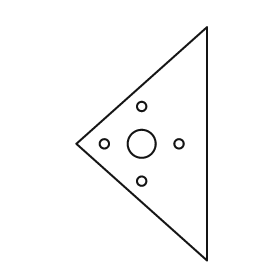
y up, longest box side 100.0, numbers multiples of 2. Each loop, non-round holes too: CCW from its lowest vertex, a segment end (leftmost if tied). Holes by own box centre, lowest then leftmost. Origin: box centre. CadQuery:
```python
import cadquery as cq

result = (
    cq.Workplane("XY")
    .moveTo(28.0, -50.0)
    .lineTo(28.0, 50.0)
    .lineTo(-28.0, 0.0)
    .close()
    .moveTo(0.0, -16.0)
    .circle(2.0)
    .moveTo(-16.0, 0.0)
    .circle(2.0)
    .moveTo(0.0, 0.0)
    .circle(6.0)
    .moveTo(16.0, 0.0)
    .circle(2.0)
    .moveTo(0.0, 16.0)
    .circle(2.0)
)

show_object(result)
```